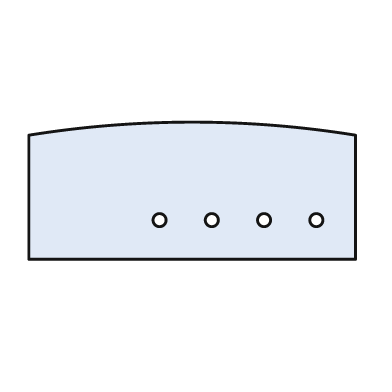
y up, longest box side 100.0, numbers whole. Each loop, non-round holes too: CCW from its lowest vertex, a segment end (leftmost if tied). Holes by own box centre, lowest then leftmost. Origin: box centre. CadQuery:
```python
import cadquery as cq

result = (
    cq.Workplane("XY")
    .moveTo(-50.0, -21.0)
    .lineTo(50.0, -21.0)
    .lineTo(50.0, 17.0)
    .threePointArc((0.0, 21.0), (-50.0, 17.0))
    .close()
    .moveTo(-10.0, -9.0)
    .circle(2.0)
    .moveTo(6.0, -9.0)
    .circle(2.0)
    .moveTo(22.0, -9.0)
    .circle(2.0)
    .moveTo(38.0, -9.0)
    .circle(2.0)
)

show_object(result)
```